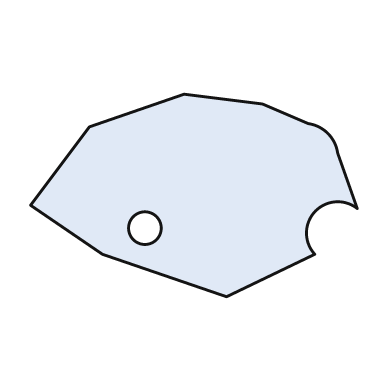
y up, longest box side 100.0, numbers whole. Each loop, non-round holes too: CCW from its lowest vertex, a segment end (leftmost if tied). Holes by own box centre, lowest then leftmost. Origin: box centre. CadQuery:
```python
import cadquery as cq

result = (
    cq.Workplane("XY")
    .moveTo(10.0, -31.0)
    .lineTo(37.0, -18.0)
    .threePointArc((37.0, -5.0), (50.0, -4.0))
    .lineTo(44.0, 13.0)
    .threePointArc((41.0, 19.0), (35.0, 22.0))
    .lineTo(21.0, 28.0)
    .lineTo(-3.0, 31.0)
    .lineTo(-32.0, 21.0)
    .lineTo(-50.0, -3.0)
    .lineTo(-28.0, -18.0)
    .close()
    .moveTo(-15.0, -10.0)
    .circle(5.0)
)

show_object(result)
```